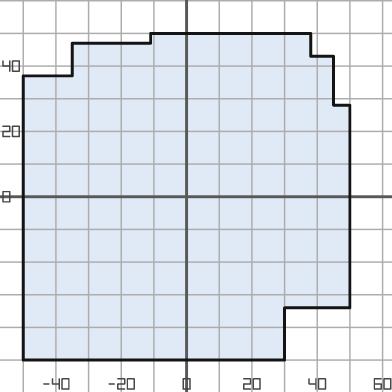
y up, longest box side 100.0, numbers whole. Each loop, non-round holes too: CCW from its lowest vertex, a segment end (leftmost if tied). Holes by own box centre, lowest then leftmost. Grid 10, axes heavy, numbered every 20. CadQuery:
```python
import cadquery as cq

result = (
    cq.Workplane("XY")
    .moveTo(-50.0, -50.0)
    .lineTo(30.0, -50.0)
    .lineTo(30.0, -34.0)
    .lineTo(50.0, -34.0)
    .lineTo(50.0, 28.0)
    .lineTo(45.0, 28.0)
    .lineTo(45.0, 43.0)
    .lineTo(38.0, 43.0)
    .lineTo(38.0, 50.0)
    .lineTo(-11.0, 50.0)
    .lineTo(-11.0, 47.0)
    .lineTo(-35.0, 47.0)
    .lineTo(-35.0, 37.0)
    .lineTo(-50.0, 37.0)
    .close()
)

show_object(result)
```